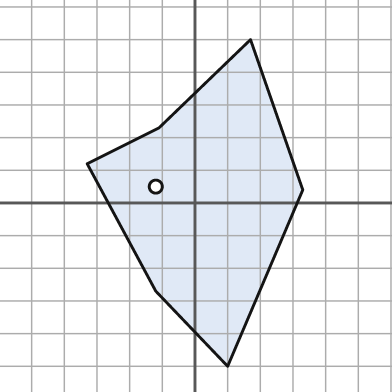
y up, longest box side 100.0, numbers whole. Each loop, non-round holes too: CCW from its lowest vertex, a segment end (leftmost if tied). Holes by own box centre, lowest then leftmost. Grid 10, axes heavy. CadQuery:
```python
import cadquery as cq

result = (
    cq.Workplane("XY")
    .moveTo(10.0, -50.0)
    .lineTo(33.0, 4.0)
    .lineTo(17.0, 50.0)
    .lineTo(-11.0, 23.0)
    .lineTo(-33.0, 12.0)
    .lineTo(-12.0, -27.0)
    .close()
    .moveTo(-12.0, 5.0)
    .circle(2.0)
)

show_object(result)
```